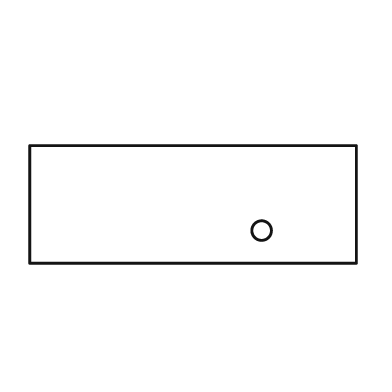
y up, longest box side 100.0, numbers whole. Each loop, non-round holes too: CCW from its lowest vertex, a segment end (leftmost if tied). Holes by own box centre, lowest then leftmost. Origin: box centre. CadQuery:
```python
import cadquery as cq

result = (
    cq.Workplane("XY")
    .moveTo(-50.0, -18.0)
    .lineTo(50.0, -18.0)
    .lineTo(50.0, 18.0)
    .lineTo(-50.0, 18.0)
    .close()
    .moveTo(21.0, -8.0)
    .circle(3.0)
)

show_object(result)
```